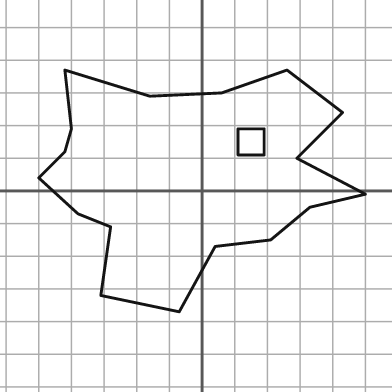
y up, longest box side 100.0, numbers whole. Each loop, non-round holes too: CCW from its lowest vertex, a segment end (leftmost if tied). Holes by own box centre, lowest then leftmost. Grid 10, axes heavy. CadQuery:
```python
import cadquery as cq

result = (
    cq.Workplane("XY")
    .moveTo(-7.0, -37.0)
    .lineTo(4.0, -17.0)
    .lineTo(21.0, -15.0)
    .lineTo(33.0, -5.0)
    .lineTo(50.0, -1.0)
    .lineTo(29.0, 10.0)
    .lineTo(43.0, 24.0)
    .lineTo(26.0, 37.0)
    .lineTo(6.0, 30.0)
    .lineTo(-16.0, 29.0)
    .lineTo(-42.0, 37.0)
    .lineTo(-40.0, 19.0)
    .lineTo(-42.0, 12.0)
    .lineTo(-50.0, 4.0)
    .lineTo(-38.0, -7.0)
    .lineTo(-28.0, -11.0)
    .lineTo(-31.0, -32.0)
    .close()
    .moveTo(11.0, 11.0)
    .lineTo(19.0, 11.0)
    .lineTo(19.0, 19.0)
    .lineTo(11.0, 19.0)
    .close()
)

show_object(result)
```